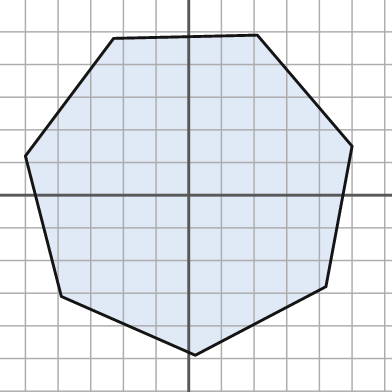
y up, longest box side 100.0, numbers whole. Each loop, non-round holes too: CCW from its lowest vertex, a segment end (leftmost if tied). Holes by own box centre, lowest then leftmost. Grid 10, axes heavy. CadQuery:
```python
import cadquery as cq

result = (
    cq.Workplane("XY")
    .moveTo(2.0, -49.0)
    .lineTo(42.0, -28.0)
    .lineTo(50.0, 15.0)
    .lineTo(21.0, 49.0)
    .lineTo(-23.0, 48.0)
    .lineTo(-50.0, 12.0)
    .lineTo(-39.0, -31.0)
    .close()
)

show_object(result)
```